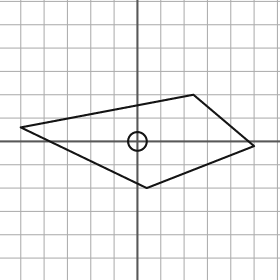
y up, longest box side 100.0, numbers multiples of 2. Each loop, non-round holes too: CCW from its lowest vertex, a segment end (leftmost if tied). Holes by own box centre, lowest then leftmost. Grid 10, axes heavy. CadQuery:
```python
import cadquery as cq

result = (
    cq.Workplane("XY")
    .moveTo(4.0, -20.0)
    .lineTo(50.0, -2.0)
    .lineTo(24.0, 20.0)
    .lineTo(-50.0, 6.0)
    .close()
    .moveTo(0.0, 0.0)
    .circle(4.0)
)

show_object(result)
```